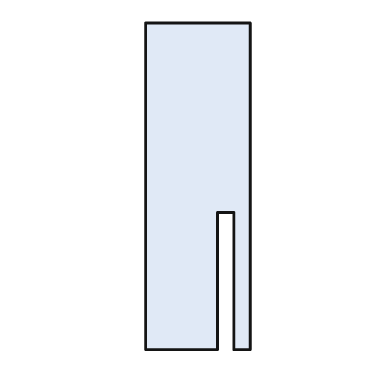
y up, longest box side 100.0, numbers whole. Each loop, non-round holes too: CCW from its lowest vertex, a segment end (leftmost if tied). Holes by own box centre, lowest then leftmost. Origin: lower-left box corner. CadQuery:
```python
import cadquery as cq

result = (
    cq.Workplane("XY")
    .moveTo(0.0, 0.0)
    .lineTo(22.0, 0.0)
    .lineTo(22.0, 42.0)
    .lineTo(27.0, 42.0)
    .lineTo(27.0, 0.0)
    .lineTo(32.0, 0.0)
    .lineTo(32.0, 100.0)
    .lineTo(0.0, 100.0)
    .close()
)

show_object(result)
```